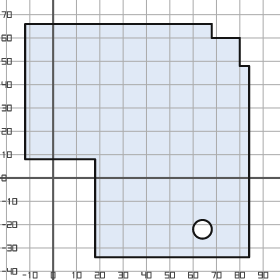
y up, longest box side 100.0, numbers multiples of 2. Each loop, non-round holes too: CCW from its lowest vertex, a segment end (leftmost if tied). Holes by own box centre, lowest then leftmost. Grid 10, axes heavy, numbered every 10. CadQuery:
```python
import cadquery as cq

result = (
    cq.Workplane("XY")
    .moveTo(18.0, -34.0)
    .lineTo(84.0, -34.0)
    .lineTo(84.0, 48.0)
    .lineTo(80.0, 48.0)
    .lineTo(80.0, 60.0)
    .lineTo(68.0, 60.0)
    .lineTo(68.0, 66.0)
    .lineTo(-12.0, 66.0)
    .lineTo(-12.0, 8.0)
    .lineTo(18.0, 8.0)
    .close()
    .moveTo(64.0, -22.0)
    .circle(4.0)
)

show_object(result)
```